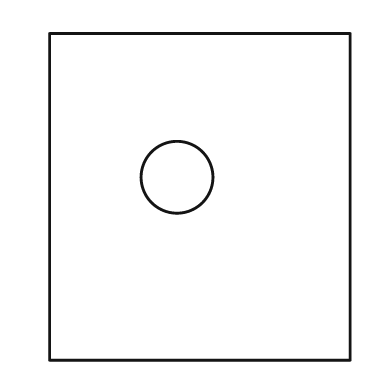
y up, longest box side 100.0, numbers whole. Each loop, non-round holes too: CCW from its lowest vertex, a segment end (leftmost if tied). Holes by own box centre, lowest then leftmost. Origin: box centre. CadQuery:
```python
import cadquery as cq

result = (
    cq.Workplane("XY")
    .moveTo(-46.0, -50.0)
    .lineTo(46.0, -50.0)
    .lineTo(46.0, 50.0)
    .lineTo(-46.0, 50.0)
    .close()
    .moveTo(-7.0, 6.0)
    .circle(11.0)
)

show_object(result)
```